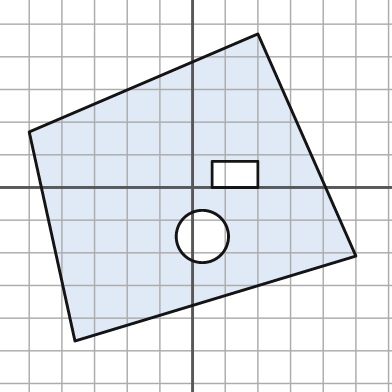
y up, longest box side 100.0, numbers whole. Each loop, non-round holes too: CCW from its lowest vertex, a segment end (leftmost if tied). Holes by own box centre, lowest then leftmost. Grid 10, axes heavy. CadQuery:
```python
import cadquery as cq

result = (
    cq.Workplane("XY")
    .moveTo(-36.0, -47.0)
    .lineTo(50.0, -21.0)
    .lineTo(20.0, 47.0)
    .lineTo(-50.0, 17.0)
    .close()
    .moveTo(3.0, -15.0)
    .circle(8.0)
    .moveTo(6.0, 0.0)
    .lineTo(20.0, 0.0)
    .lineTo(20.0, 8.0)
    .lineTo(6.0, 8.0)
    .close()
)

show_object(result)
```